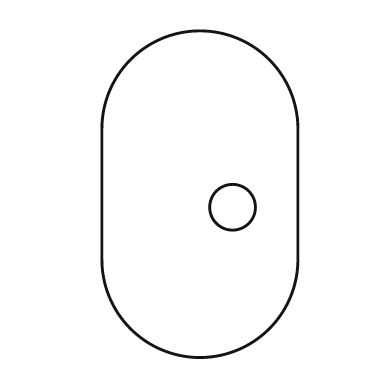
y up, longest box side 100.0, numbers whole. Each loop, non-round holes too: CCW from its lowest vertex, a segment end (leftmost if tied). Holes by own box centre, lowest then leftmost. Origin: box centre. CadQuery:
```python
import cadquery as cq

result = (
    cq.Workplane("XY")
    .moveTo(-30.0, -20.0)
    .threePointArc((0.0, -50.0), (30.0, -20.0))
    .lineTo(30.0, 20.0)
    .threePointArc((0.0, 50.0), (-30.0, 20.0))
    .close()
    .moveTo(10.0, -4.0)
    .circle(7.0)
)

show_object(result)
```